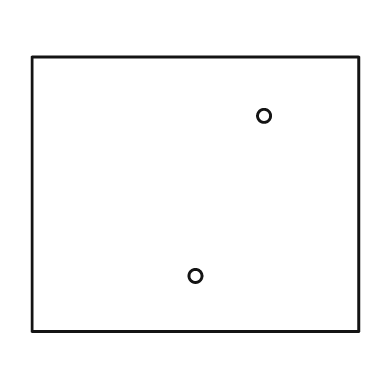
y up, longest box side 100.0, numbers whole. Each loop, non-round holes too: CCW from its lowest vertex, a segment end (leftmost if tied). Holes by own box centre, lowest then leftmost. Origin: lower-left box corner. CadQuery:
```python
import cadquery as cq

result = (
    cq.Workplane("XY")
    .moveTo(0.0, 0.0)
    .lineTo(100.0, 0.0)
    .lineTo(100.0, 84.0)
    .lineTo(0.0, 84.0)
    .close()
    .moveTo(50.0, 17.0)
    .circle(2.0)
    .moveTo(71.0, 66.0)
    .circle(2.0)
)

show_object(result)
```